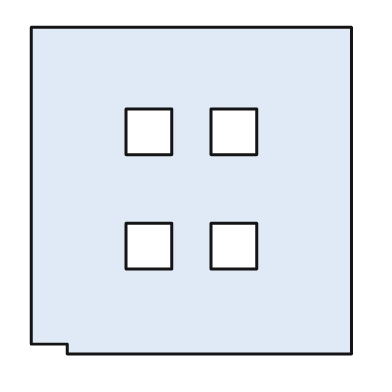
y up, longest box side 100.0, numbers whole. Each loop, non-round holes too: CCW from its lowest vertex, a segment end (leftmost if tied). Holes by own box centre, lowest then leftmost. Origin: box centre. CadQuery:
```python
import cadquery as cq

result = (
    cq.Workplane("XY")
    .moveTo(-38.0, -50.0)
    .lineTo(49.0, -50.0)
    .lineTo(49.0, 50.0)
    .lineTo(-49.0, 50.0)
    .lineTo(-49.0, -47.0)
    .lineTo(-38.0, -47.0)
    .close()
    .moveTo(-20.0, -24.0)
    .lineTo(-6.0, -24.0)
    .lineTo(-6.0, -10.0)
    .lineTo(-20.0, -10.0)
    .close()
    .moveTo(6.0, -24.0)
    .lineTo(20.0, -24.0)
    .lineTo(20.0, -10.0)
    .lineTo(6.0, -10.0)
    .close()
    .moveTo(-20.0, 11.0)
    .lineTo(-6.0, 11.0)
    .lineTo(-6.0, 25.0)
    .lineTo(-20.0, 25.0)
    .close()
    .moveTo(6.0, 11.0)
    .lineTo(20.0, 11.0)
    .lineTo(20.0, 25.0)
    .lineTo(6.0, 25.0)
    .close()
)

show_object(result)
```